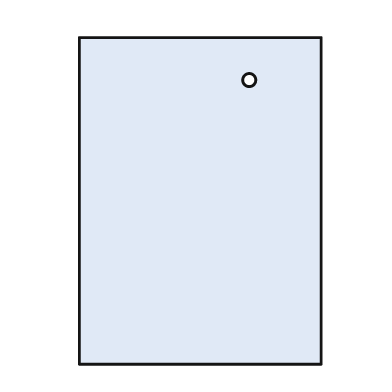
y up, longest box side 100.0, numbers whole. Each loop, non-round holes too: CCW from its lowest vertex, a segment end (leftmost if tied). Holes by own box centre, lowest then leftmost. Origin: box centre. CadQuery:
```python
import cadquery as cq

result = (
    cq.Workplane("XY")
    .moveTo(-37.0, -50.0)
    .lineTo(37.0, -50.0)
    .lineTo(37.0, 50.0)
    .lineTo(-37.0, 50.0)
    .close()
    .moveTo(15.0, 37.0)
    .circle(2.0)
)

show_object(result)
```